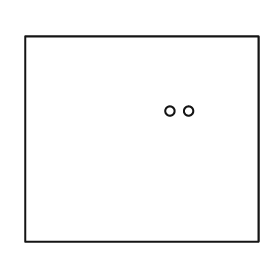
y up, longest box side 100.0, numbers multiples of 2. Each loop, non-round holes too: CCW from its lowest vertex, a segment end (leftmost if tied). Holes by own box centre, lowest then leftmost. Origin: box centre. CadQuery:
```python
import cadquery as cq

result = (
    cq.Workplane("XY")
    .moveTo(-50.0, -44.0)
    .lineTo(50.0, -44.0)
    .lineTo(50.0, 44.0)
    .lineTo(-50.0, 44.0)
    .close()
    .moveTo(12.0, 12.0)
    .circle(2.0)
    .moveTo(20.0, 12.0)
    .circle(2.0)
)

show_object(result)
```